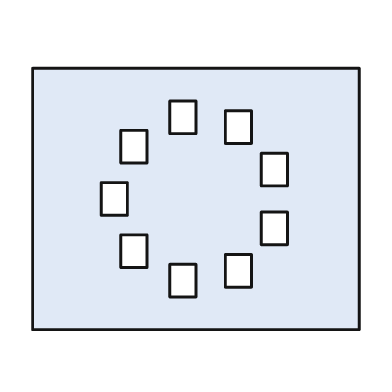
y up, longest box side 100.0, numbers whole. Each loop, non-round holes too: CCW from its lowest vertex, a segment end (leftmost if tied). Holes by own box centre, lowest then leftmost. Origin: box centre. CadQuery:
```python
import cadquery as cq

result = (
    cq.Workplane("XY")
    .moveTo(-50.0, -40.0)
    .lineTo(50.0, -40.0)
    .lineTo(50.0, 40.0)
    .lineTo(-50.0, 40.0)
    .close()
    .moveTo(-8.0, -30.0)
    .lineTo(0.0, -30.0)
    .lineTo(0.0, -20.0)
    .lineTo(-8.0, -20.0)
    .close()
    .moveTo(9.0, -27.0)
    .lineTo(17.0, -27.0)
    .lineTo(17.0, -17.0)
    .lineTo(9.0, -17.0)
    .close()
    .moveTo(-23.0, -21.0)
    .lineTo(-15.0, -21.0)
    .lineTo(-15.0, -11.0)
    .lineTo(-23.0, -11.0)
    .close()
    .moveTo(20.0, -14.0)
    .lineTo(28.0, -14.0)
    .lineTo(28.0, -4.0)
    .lineTo(20.0, -4.0)
    .close()
    .moveTo(-29.0, -5.0)
    .lineTo(-21.0, -5.0)
    .lineTo(-21.0, 5.0)
    .lineTo(-29.0, 5.0)
    .close()
    .moveTo(20.0, 4.0)
    .lineTo(28.0, 4.0)
    .lineTo(28.0, 14.0)
    .lineTo(20.0, 14.0)
    .close()
    .moveTo(-23.0, 11.0)
    .lineTo(-15.0, 11.0)
    .lineTo(-15.0, 21.0)
    .lineTo(-23.0, 21.0)
    .close()
    .moveTo(9.0, 17.0)
    .lineTo(17.0, 17.0)
    .lineTo(17.0, 27.0)
    .lineTo(9.0, 27.0)
    .close()
    .moveTo(-8.0, 20.0)
    .lineTo(0.0, 20.0)
    .lineTo(0.0, 30.0)
    .lineTo(-8.0, 30.0)
    .close()
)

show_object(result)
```